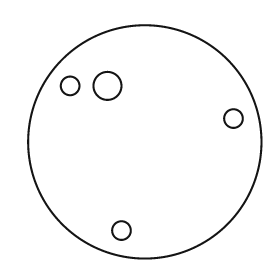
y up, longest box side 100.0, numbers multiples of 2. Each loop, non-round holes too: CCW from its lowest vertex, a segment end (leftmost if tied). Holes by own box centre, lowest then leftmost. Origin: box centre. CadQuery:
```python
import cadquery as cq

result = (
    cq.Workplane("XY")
    .moveTo(0.0, 0.0)
    .circle(50.0)
    .moveTo(-10.0, -38.0)
    .circle(4.0)
    .moveTo(38.0, 10.0)
    .circle(4.0)
    .moveTo(-32.0, 24.0)
    .circle(4.0)
    .moveTo(-16.0, 24.0)
    .circle(6.0)
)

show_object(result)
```